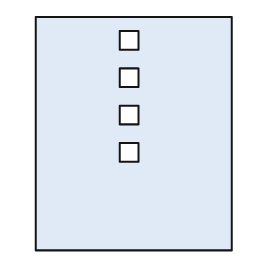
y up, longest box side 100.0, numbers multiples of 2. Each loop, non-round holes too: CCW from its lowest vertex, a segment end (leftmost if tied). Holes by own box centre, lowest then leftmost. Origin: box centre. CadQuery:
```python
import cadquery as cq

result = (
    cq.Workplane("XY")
    .moveTo(-42.0, -50.0)
    .lineTo(42.0, -50.0)
    .lineTo(42.0, 50.0)
    .lineTo(-42.0, 50.0)
    .close()
    .moveTo(-6.0, -12.0)
    .lineTo(2.0, -12.0)
    .lineTo(2.0, -4.0)
    .lineTo(-6.0, -4.0)
    .close()
    .moveTo(-6.0, 4.0)
    .lineTo(2.0, 4.0)
    .lineTo(2.0, 12.0)
    .lineTo(-6.0, 12.0)
    .close()
    .moveTo(-6.0, 20.0)
    .lineTo(2.0, 20.0)
    .lineTo(2.0, 28.0)
    .lineTo(-6.0, 28.0)
    .close()
    .moveTo(-6.0, 36.0)
    .lineTo(2.0, 36.0)
    .lineTo(2.0, 44.0)
    .lineTo(-6.0, 44.0)
    .close()
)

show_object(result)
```